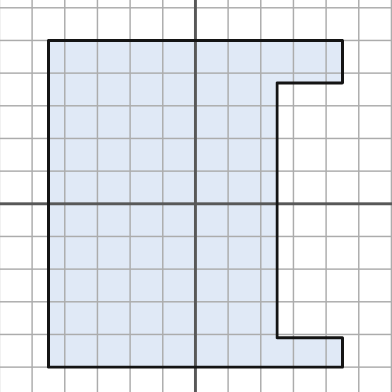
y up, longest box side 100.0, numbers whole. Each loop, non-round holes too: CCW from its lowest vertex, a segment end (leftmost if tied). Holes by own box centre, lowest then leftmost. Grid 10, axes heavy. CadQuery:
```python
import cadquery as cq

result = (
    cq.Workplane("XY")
    .moveTo(-45.0, -50.0)
    .lineTo(45.0, -50.0)
    .lineTo(45.0, -41.0)
    .lineTo(25.0, -41.0)
    .lineTo(25.0, 37.0)
    .lineTo(45.0, 37.0)
    .lineTo(45.0, 50.0)
    .lineTo(-45.0, 50.0)
    .close()
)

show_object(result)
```